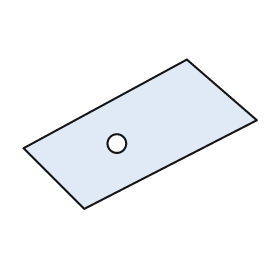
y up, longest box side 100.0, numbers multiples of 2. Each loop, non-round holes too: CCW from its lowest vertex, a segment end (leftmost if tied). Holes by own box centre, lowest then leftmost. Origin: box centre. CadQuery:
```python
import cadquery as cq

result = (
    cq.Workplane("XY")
    .moveTo(-24.0, -32.0)
    .lineTo(50.0, 6.0)
    .lineTo(20.0, 32.0)
    .lineTo(-50.0, -6.0)
    .close()
    .moveTo(-10.0, -4.0)
    .circle(4.0)
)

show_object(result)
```